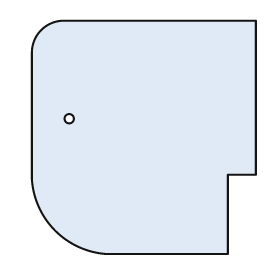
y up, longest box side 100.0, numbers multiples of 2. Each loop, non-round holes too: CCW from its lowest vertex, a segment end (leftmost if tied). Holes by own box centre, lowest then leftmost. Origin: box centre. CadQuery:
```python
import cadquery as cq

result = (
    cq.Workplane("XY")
    .moveTo(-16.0, -50.0)
    .lineTo(36.0, -50.0)
    .lineTo(36.0, -16.0)
    .lineTo(48.0, -16.0)
    .lineTo(48.0, 50.0)
    .lineTo(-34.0, 50.0)
    .threePointArc((-44.0, 46.0), (-48.0, 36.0))
    .lineTo(-48.0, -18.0)
    .threePointArc((-38.0, -40.0), (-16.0, -50.0))
    .close()
    .moveTo(-32.0, 8.0)
    .circle(2.0)
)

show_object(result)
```